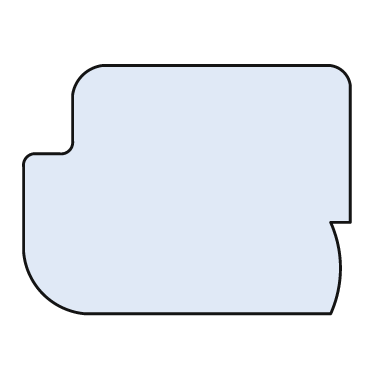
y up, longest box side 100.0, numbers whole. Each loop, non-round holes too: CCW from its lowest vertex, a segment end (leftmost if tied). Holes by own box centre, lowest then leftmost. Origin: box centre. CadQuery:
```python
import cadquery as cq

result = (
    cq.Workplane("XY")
    .moveTo(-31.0, -38.0)
    .lineTo(44.0, -38.0)
    .threePointArc((47.0, -24.0), (44.0, -10.0))
    .lineTo(50.0, -10.0)
    .lineTo(50.0, 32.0)
    .threePointArc((48.0, 36.0), (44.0, 38.0))
    .lineTo(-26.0, 38.0)
    .threePointArc((-32.0, 35.0), (-35.0, 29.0))
    .lineTo(-35.0, 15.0)
    .threePointArc((-36.0, 12.0), (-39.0, 11.0))
    .lineTo(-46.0, 11.0)
    .threePointArc((-49.0, 10.0), (-50.0, 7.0))
    .lineTo(-50.0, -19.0)
    .threePointArc((-44.0, -32.0), (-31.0, -38.0))
    .close()
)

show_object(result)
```